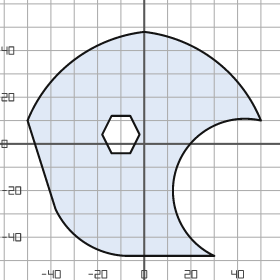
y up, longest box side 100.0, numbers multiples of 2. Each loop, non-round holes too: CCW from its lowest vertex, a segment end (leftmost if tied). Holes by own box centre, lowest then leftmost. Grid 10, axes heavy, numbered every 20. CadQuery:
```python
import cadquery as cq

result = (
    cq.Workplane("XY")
    .moveTo(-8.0, -48.0)
    .lineTo(30.0, -48.0)
    .threePointArc((14.0, -10.0), (50.0, 10.0))
    .threePointArc((30.0, 36.0), (0.0, 48.0))
    .threePointArc((-30.0, 36.0), (-50.0, 10.0))
    .lineTo(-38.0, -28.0)
    .threePointArc((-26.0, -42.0), (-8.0, -48.0))
    .close()
    .moveTo(-14.0, -4.0)
    .lineTo(-6.0, -4.0)
    .lineTo(-2.0, 4.0)
    .lineTo(-6.0, 12.0)
    .lineTo(-14.0, 12.0)
    .lineTo(-18.0, 4.0)
    .close()
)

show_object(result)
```